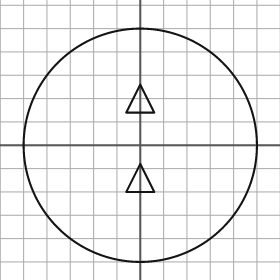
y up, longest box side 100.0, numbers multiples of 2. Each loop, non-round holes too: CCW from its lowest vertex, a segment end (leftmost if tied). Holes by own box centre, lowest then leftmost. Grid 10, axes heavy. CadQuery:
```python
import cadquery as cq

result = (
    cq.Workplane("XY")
    .moveTo(0.0, 0.0)
    .circle(50.0)
    .moveTo(-6.0, -20.0)
    .lineTo(6.0, -20.0)
    .lineTo(0.0, -8.0)
    .close()
    .moveTo(-6.0, 14.0)
    .lineTo(6.0, 14.0)
    .lineTo(0.0, 26.0)
    .close()
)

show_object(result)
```